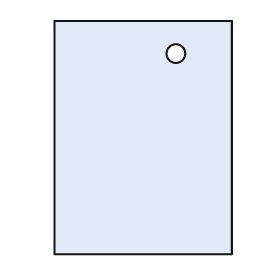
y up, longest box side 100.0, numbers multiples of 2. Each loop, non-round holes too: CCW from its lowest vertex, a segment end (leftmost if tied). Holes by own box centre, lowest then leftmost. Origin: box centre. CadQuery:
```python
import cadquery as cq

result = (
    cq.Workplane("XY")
    .moveTo(-38.0, -50.0)
    .lineTo(38.0, -50.0)
    .lineTo(38.0, 50.0)
    .lineTo(-38.0, 50.0)
    .close()
    .moveTo(14.0, 36.0)
    .circle(4.0)
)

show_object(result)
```